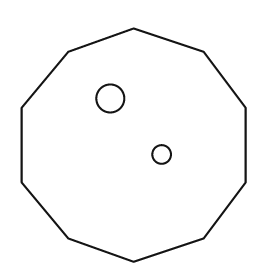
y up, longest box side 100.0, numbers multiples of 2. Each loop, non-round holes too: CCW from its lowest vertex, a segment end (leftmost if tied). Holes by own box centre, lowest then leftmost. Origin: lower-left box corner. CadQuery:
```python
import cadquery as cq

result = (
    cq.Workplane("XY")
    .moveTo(48.0, 0.0)
    .lineTo(78.0, 10.0)
    .lineTo(96.0, 34.0)
    .lineTo(96.0, 66.0)
    .lineTo(78.0, 90.0)
    .lineTo(48.0, 100.0)
    .lineTo(20.0, 90.0)
    .lineTo(0.0, 66.0)
    .lineTo(0.0, 34.0)
    .lineTo(20.0, 10.0)
    .close()
    .moveTo(60.0, 46.0)
    .circle(4.0)
    .moveTo(38.0, 70.0)
    .circle(6.0)
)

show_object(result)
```